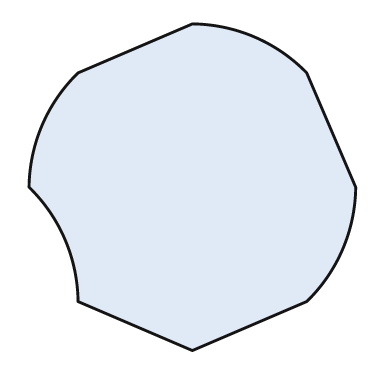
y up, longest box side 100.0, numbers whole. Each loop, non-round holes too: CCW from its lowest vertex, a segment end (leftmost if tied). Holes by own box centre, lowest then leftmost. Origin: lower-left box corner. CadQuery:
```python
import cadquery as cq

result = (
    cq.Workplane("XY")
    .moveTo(50.0, 0.0)
    .lineTo(85.0, 15.0)
    .threePointArc((96.0, 31.0), (100.0, 50.0))
    .lineTo(85.0, 85.0)
    .threePointArc((69.0, 96.0), (50.0, 100.0))
    .lineTo(15.0, 85.0)
    .threePointArc((4.0, 69.0), (0.0, 50.0))
    .threePointArc((11.0, 34.0), (15.0, 15.0))
    .close()
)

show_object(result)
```